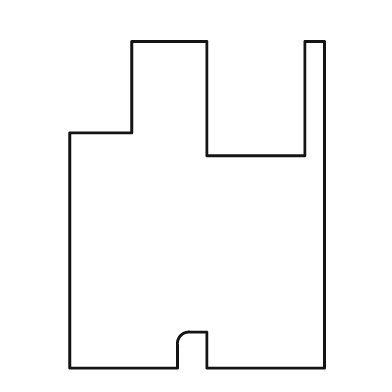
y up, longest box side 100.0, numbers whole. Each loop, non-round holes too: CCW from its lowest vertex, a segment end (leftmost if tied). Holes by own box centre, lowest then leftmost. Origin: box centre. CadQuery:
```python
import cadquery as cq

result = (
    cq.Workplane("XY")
    .moveTo(-39.0, -50.0)
    .lineTo(-6.0, -50.0)
    .lineTo(-6.0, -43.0)
    .threePointArc((-5.0, -40.0), (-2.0, -39.0))
    .lineTo(3.0, -39.0)
    .lineTo(3.0, -50.0)
    .lineTo(39.0, -50.0)
    .lineTo(39.0, 50.0)
    .lineTo(33.0, 50.0)
    .lineTo(33.0, 15.0)
    .lineTo(3.0, 15.0)
    .lineTo(3.0, 50.0)
    .lineTo(-20.0, 50.0)
    .lineTo(-20.0, 22.0)
    .lineTo(-39.0, 22.0)
    .close()
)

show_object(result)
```